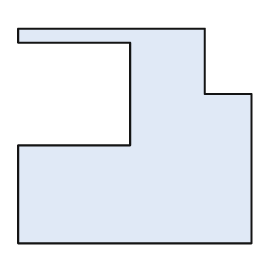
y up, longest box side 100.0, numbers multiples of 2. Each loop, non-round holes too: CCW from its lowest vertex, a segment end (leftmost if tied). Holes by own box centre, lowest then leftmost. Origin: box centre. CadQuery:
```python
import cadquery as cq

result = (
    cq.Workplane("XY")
    .moveTo(-50.0, -46.0)
    .lineTo(50.0, -46.0)
    .lineTo(50.0, 18.0)
    .lineTo(30.0, 18.0)
    .lineTo(30.0, 46.0)
    .lineTo(-50.0, 46.0)
    .lineTo(-50.0, 40.0)
    .lineTo(-2.0, 40.0)
    .lineTo(-2.0, -4.0)
    .lineTo(-50.0, -4.0)
    .close()
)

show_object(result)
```